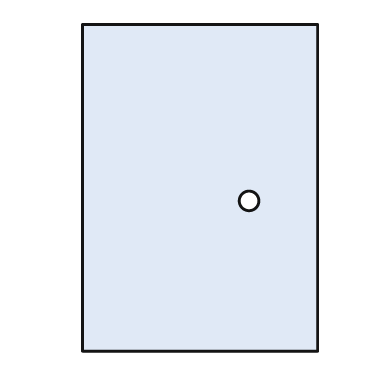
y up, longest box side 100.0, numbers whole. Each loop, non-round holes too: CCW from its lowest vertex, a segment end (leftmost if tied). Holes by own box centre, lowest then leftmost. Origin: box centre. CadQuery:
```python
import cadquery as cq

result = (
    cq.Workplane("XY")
    .moveTo(-36.0, -50.0)
    .lineTo(36.0, -50.0)
    .lineTo(36.0, 50.0)
    .lineTo(-36.0, 50.0)
    .close()
    .moveTo(15.0, -4.0)
    .circle(3.0)
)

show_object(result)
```